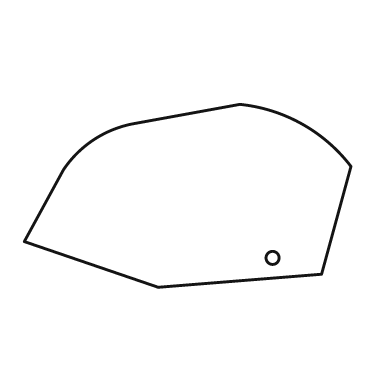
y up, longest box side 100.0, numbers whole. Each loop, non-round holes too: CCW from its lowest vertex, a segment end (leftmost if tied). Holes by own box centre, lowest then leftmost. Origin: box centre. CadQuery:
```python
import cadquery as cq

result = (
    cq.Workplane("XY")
    .moveTo(-9.0, -28.0)
    .lineTo(41.0, -24.0)
    .lineTo(50.0, 9.0)
    .threePointArc((35.0, 22.0), (16.0, 28.0))
    .lineTo(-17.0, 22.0)
    .threePointArc((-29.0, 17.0), (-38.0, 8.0))
    .lineTo(-50.0, -14.0)
    .close()
    .moveTo(26.0, -19.0)
    .circle(2.0)
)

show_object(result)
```